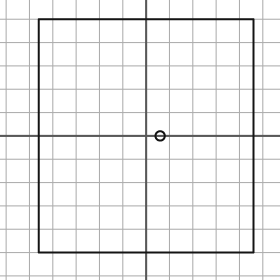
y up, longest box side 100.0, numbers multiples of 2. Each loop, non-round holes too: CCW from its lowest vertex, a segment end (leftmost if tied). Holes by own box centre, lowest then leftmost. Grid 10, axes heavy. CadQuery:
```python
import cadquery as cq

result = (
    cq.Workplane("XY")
    .moveTo(-46.0, -50.0)
    .lineTo(46.0, -50.0)
    .lineTo(46.0, 50.0)
    .lineTo(-46.0, 50.0)
    .close()
    .moveTo(6.0, 0.0)
    .circle(2.0)
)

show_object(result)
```